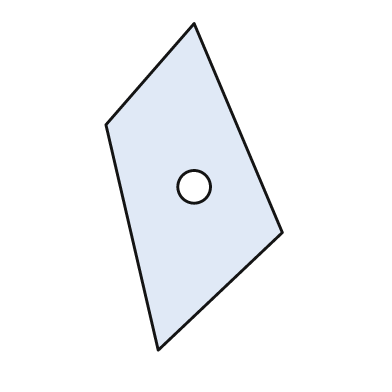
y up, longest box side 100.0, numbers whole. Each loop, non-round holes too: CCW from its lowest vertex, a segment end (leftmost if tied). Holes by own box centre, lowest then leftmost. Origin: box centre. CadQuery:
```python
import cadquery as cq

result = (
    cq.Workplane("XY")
    .moveTo(-11.0, -50.0)
    .lineTo(27.0, -14.0)
    .lineTo(0.0, 50.0)
    .lineTo(-27.0, 19.0)
    .close()
    .moveTo(0.0, 0.0)
    .circle(5.0)
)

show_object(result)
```